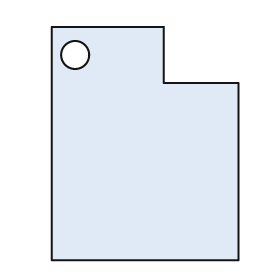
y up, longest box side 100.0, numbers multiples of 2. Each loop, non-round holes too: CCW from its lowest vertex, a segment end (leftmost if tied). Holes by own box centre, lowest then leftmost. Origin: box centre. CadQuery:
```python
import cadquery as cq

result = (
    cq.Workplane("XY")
    .moveTo(-40.0, -50.0)
    .lineTo(40.0, -50.0)
    .lineTo(40.0, 26.0)
    .lineTo(8.0, 26.0)
    .lineTo(8.0, 50.0)
    .lineTo(-40.0, 50.0)
    .close()
    .moveTo(-30.0, 38.0)
    .circle(6.0)
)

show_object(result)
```